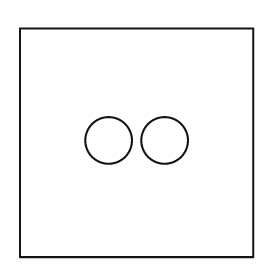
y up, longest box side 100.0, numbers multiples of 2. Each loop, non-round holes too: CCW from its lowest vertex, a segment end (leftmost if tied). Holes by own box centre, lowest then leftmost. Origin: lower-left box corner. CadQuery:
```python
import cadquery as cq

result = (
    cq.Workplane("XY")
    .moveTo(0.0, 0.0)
    .lineTo(100.0, 0.0)
    .lineTo(100.0, 98.0)
    .lineTo(0.0, 98.0)
    .close()
    .moveTo(38.0, 50.0)
    .circle(10.0)
    .moveTo(62.0, 50.0)
    .circle(10.0)
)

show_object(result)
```